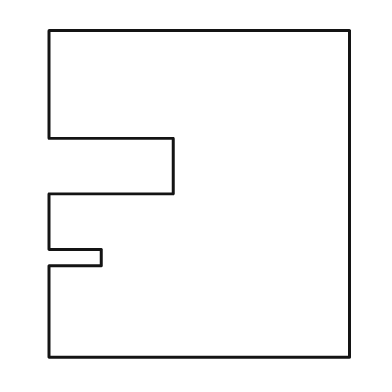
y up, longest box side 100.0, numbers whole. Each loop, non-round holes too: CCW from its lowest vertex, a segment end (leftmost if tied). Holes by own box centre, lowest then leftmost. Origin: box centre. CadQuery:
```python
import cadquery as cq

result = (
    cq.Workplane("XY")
    .moveTo(-46.0, -50.0)
    .lineTo(46.0, -50.0)
    .lineTo(46.0, 50.0)
    .lineTo(-46.0, 50.0)
    .lineTo(-46.0, 17.0)
    .lineTo(-8.0, 17.0)
    .lineTo(-8.0, 0.0)
    .lineTo(-46.0, 0.0)
    .lineTo(-46.0, -17.0)
    .lineTo(-30.0, -17.0)
    .lineTo(-30.0, -22.0)
    .lineTo(-46.0, -22.0)
    .close()
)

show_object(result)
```